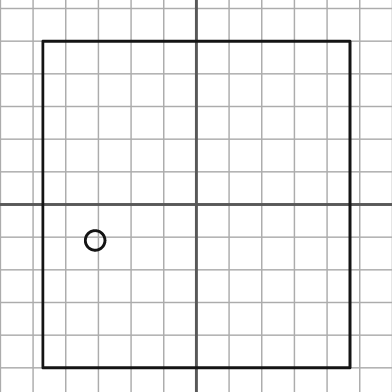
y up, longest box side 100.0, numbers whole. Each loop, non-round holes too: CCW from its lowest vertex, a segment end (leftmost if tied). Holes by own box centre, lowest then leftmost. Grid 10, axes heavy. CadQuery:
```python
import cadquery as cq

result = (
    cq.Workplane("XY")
    .moveTo(-47.0, -50.0)
    .lineTo(47.0, -50.0)
    .lineTo(47.0, 50.0)
    .lineTo(-47.0, 50.0)
    .close()
    .moveTo(-31.0, -11.0)
    .circle(3.0)
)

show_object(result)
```